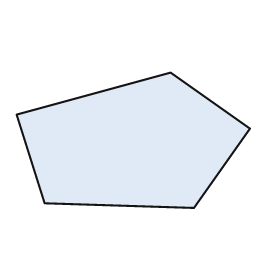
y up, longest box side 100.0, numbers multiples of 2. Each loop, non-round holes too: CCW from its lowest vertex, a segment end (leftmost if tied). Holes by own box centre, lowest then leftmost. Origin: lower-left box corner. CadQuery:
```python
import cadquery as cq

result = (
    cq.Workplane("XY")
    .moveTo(76.0, 0.0)
    .lineTo(100.0, 34.0)
    .lineTo(66.0, 58.0)
    .lineTo(0.0, 40.0)
    .lineTo(12.0, 2.0)
    .close()
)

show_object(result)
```